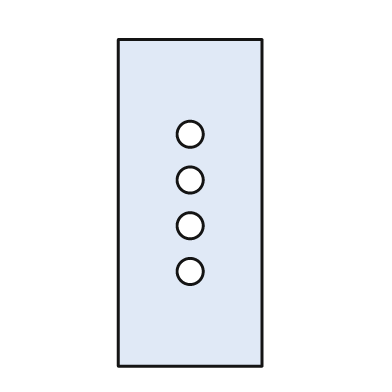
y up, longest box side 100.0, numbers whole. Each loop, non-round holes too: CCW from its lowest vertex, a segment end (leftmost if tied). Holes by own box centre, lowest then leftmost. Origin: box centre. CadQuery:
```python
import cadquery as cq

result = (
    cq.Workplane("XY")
    .moveTo(-22.0, -50.0)
    .lineTo(22.0, -50.0)
    .lineTo(22.0, 50.0)
    .lineTo(-22.0, 50.0)
    .close()
    .moveTo(0.0, -21.0)
    .circle(4.0)
    .moveTo(0.0, -7.0)
    .circle(4.0)
    .moveTo(0.0, 7.0)
    .circle(4.0)
    .moveTo(0.0, 21.0)
    .circle(4.0)
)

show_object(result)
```